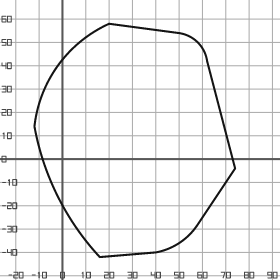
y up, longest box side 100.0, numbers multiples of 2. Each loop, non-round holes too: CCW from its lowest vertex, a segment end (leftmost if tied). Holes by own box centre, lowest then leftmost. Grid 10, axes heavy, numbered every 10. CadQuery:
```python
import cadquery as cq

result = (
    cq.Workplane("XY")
    .moveTo(16.0, -42.0)
    .lineTo(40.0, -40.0)
    .threePointArc((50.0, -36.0), (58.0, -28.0))
    .lineTo(74.0, -4.0)
    .lineTo(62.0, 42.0)
    .threePointArc((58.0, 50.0), (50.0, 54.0))
    .lineTo(20.0, 58.0)
    .threePointArc((-2.0, 40.0), (-12.0, 14.0))
    .threePointArc((-2.0, -16.0), (16.0, -42.0))
    .close()
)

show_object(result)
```